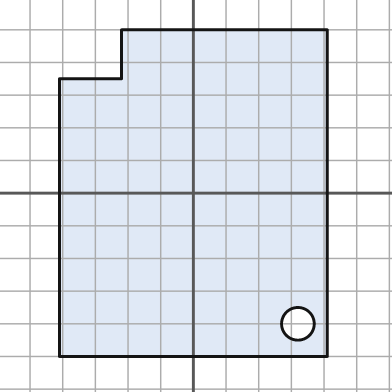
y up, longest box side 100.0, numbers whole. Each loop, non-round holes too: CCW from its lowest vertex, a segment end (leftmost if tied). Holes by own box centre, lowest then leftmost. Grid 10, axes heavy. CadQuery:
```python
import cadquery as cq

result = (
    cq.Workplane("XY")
    .moveTo(-41.0, -50.0)
    .lineTo(41.0, -50.0)
    .lineTo(41.0, 50.0)
    .lineTo(-22.0, 50.0)
    .lineTo(-22.0, 35.0)
    .lineTo(-41.0, 35.0)
    .close()
    .moveTo(32.0, -40.0)
    .circle(5.0)
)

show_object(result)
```